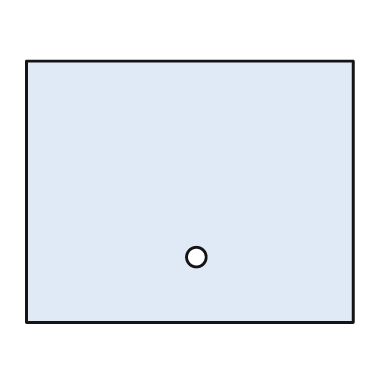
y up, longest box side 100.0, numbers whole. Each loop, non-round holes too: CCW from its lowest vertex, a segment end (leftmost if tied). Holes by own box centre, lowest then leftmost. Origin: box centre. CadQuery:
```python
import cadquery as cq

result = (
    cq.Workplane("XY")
    .moveTo(-50.0, -40.0)
    .lineTo(50.0, -40.0)
    .lineTo(50.0, 40.0)
    .lineTo(-50.0, 40.0)
    .close()
    .moveTo(2.0, -20.0)
    .circle(3.0)
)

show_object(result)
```